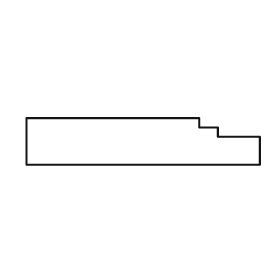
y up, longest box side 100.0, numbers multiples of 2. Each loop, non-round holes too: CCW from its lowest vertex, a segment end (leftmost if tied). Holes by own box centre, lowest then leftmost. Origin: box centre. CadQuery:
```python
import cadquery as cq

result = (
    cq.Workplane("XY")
    .moveTo(-50.0, -10.0)
    .lineTo(50.0, -10.0)
    .lineTo(50.0, 2.0)
    .lineTo(32.0, 2.0)
    .lineTo(32.0, 6.0)
    .lineTo(24.0, 6.0)
    .lineTo(24.0, 10.0)
    .lineTo(-50.0, 10.0)
    .close()
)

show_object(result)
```